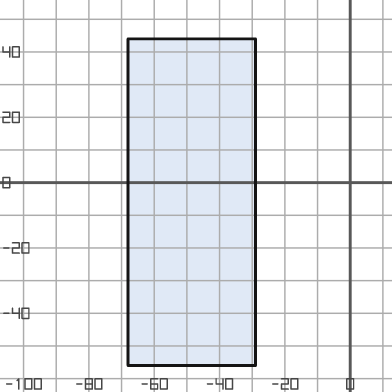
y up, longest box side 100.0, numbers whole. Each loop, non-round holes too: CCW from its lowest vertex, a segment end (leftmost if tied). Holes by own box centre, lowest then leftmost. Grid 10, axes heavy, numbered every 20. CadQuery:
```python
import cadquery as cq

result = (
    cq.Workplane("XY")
    .moveTo(-68.0, -56.0)
    .lineTo(-29.0, -56.0)
    .lineTo(-29.0, 44.0)
    .lineTo(-68.0, 44.0)
    .close()
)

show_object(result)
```